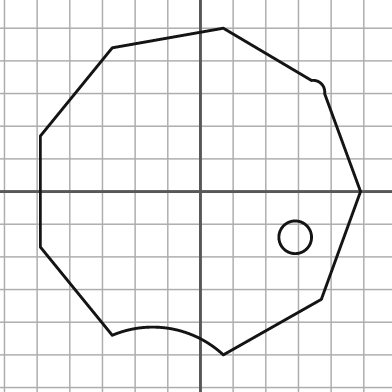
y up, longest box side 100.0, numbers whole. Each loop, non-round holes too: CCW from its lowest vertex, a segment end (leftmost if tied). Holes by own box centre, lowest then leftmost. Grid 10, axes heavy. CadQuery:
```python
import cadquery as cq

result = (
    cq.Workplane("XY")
    .moveTo(7.0, -50.0)
    .lineTo(37.0, -33.0)
    .lineTo(49.0, 0.0)
    .lineTo(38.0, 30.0)
    .threePointArc((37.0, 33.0), (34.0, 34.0))
    .lineTo(7.0, 50.0)
    .lineTo(-27.0, 44.0)
    .lineTo(-49.0, 17.0)
    .lineTo(-49.0, -17.0)
    .lineTo(-27.0, -44.0)
    .threePointArc((-9.0, -42.0), (7.0, -50.0))
    .close()
    .moveTo(29.0, -14.0)
    .circle(5.0)
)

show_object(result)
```